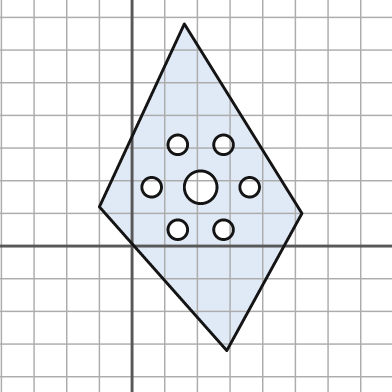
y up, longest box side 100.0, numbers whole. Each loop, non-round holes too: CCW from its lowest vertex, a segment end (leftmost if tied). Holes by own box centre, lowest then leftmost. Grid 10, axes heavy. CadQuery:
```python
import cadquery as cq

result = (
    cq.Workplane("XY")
    .moveTo(29.0, -32.0)
    .lineTo(52.0, 10.0)
    .lineTo(16.0, 68.0)
    .lineTo(-10.0, 12.0)
    .close()
    .moveTo(14.0, 5.0)
    .circle(3.0)
    .moveTo(28.0, 5.0)
    .circle(3.0)
    .moveTo(6.0, 18.0)
    .circle(3.0)
    .moveTo(21.0, 18.0)
    .circle(5.0)
    .moveTo(36.0, 18.0)
    .circle(3.0)
    .moveTo(14.0, 31.0)
    .circle(3.0)
    .moveTo(28.0, 31.0)
    .circle(3.0)
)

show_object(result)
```